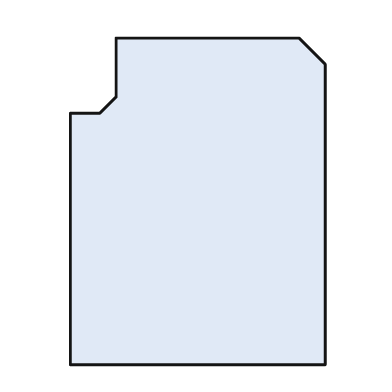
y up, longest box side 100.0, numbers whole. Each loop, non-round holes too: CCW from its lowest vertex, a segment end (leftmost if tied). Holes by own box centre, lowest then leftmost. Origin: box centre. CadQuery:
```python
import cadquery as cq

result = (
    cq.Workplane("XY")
    .moveTo(-39.0, -50.0)
    .lineTo(39.0, -50.0)
    .lineTo(39.0, 42.0)
    .lineTo(31.0, 50.0)
    .lineTo(-25.0, 50.0)
    .lineTo(-25.0, 32.0)
    .lineTo(-30.0, 27.0)
    .lineTo(-39.0, 27.0)
    .close()
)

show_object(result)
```